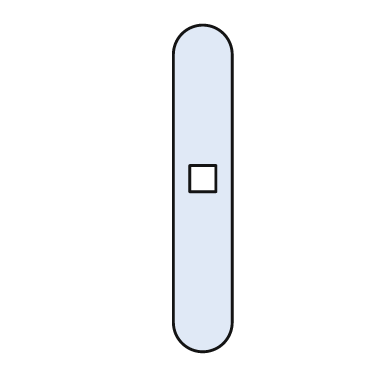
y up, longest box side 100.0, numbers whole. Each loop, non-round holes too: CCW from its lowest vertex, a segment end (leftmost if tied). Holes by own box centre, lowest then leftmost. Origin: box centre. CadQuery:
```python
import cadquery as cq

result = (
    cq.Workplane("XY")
    .moveTo(-9.0, -41.0)
    .threePointArc((0.0, -50.0), (9.0, -41.0))
    .lineTo(9.0, 41.0)
    .threePointArc((0.0, 50.0), (-9.0, 41.0))
    .close()
    .moveTo(-4.0, -1.0)
    .lineTo(4.0, -1.0)
    .lineTo(4.0, 7.0)
    .lineTo(-4.0, 7.0)
    .close()
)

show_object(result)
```